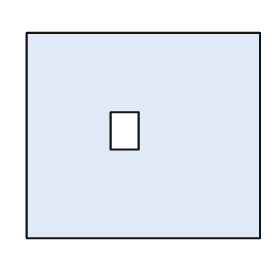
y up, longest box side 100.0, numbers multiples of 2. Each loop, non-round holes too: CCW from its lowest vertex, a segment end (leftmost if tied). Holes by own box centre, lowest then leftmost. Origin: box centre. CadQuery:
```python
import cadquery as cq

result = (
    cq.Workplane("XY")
    .moveTo(-50.0, -44.0)
    .lineTo(50.0, -44.0)
    .lineTo(50.0, 44.0)
    .lineTo(-50.0, 44.0)
    .close()
    .moveTo(-14.0, -6.0)
    .lineTo(-2.0, -6.0)
    .lineTo(-2.0, 10.0)
    .lineTo(-14.0, 10.0)
    .close()
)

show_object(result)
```